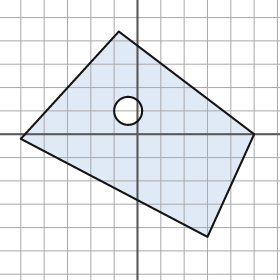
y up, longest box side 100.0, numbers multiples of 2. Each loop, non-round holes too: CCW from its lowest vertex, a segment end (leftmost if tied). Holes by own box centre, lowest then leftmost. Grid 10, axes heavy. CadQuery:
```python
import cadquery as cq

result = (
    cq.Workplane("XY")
    .moveTo(30.0, -44.0)
    .lineTo(50.0, 0.0)
    .lineTo(-8.0, 44.0)
    .lineTo(-50.0, -2.0)
    .close()
    .moveTo(-4.0, 10.0)
    .circle(6.0)
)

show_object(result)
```